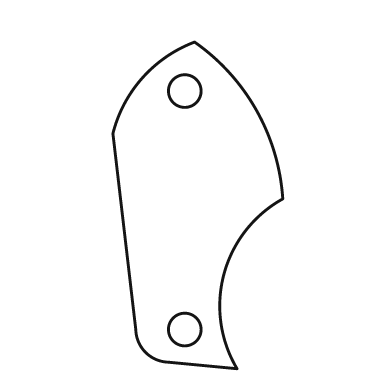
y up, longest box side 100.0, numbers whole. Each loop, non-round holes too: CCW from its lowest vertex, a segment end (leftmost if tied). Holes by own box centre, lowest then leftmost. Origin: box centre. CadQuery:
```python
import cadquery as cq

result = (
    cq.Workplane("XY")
    .moveTo(12.0, -50.0)
    .threePointArc((8.0, -21.0), (26.0, 2.0))
    .threePointArc((18.0, 29.0), (-1.0, 50.0))
    .threePointArc((-17.0, 39.0), (-26.0, 22.0))
    .lineTo(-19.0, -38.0)
    .threePointArc((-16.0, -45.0), (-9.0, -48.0))
    .close()
    .moveTo(-4.0, -38.0)
    .circle(5.0)
    .moveTo(-4.0, 35.0)
    .circle(5.0)
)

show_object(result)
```